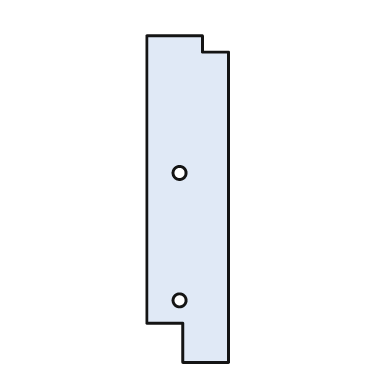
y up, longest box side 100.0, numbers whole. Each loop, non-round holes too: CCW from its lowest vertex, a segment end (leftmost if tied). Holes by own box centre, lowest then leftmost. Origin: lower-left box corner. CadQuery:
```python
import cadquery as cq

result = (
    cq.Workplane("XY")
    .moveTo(11.0, 0.0)
    .lineTo(25.0, 0.0)
    .lineTo(25.0, 95.0)
    .lineTo(17.0, 95.0)
    .lineTo(17.0, 100.0)
    .lineTo(0.0, 100.0)
    .lineTo(0.0, 12.0)
    .lineTo(11.0, 12.0)
    .close()
    .moveTo(10.0, 19.0)
    .circle(2.0)
    .moveTo(10.0, 58.0)
    .circle(2.0)
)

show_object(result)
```